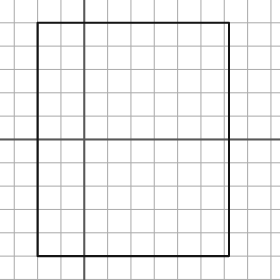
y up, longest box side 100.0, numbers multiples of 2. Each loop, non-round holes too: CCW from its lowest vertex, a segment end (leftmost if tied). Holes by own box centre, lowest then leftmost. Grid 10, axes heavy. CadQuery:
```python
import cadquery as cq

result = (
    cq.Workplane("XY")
    .moveTo(-20.0, -50.0)
    .lineTo(62.0, -50.0)
    .lineTo(62.0, 50.0)
    .lineTo(-20.0, 50.0)
    .close()
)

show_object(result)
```